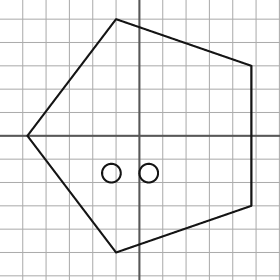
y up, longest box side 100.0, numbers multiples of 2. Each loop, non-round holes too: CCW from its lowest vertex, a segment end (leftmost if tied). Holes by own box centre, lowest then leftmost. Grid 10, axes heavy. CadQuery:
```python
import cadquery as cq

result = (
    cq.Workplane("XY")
    .moveTo(-10.0, -50.0)
    .lineTo(48.0, -30.0)
    .lineTo(48.0, 30.0)
    .lineTo(-10.0, 50.0)
    .lineTo(-48.0, 0.0)
    .close()
    .moveTo(-12.0, -16.0)
    .circle(4.0)
    .moveTo(4.0, -16.0)
    .circle(4.0)
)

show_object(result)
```